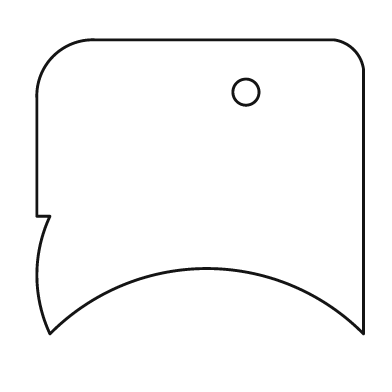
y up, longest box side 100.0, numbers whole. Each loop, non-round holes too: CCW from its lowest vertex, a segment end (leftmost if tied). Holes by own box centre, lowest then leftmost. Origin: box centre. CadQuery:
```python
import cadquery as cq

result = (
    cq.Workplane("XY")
    .moveTo(-46.0, -45.0)
    .threePointArc((2.0, -25.0), (50.0, -45.0))
    .lineTo(50.0, 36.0)
    .threePointArc((47.0, 42.0), (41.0, 45.0))
    .lineTo(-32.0, 45.0)
    .threePointArc((-45.0, 40.0), (-50.0, 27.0))
    .lineTo(-50.0, -9.0)
    .lineTo(-46.0, -9.0)
    .threePointArc((-50.0, -27.0), (-46.0, -45.0))
    .close()
    .moveTo(14.0, 29.0)
    .circle(4.0)
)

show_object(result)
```